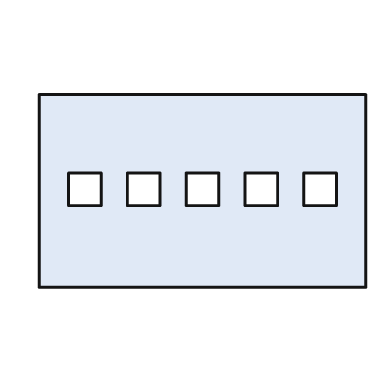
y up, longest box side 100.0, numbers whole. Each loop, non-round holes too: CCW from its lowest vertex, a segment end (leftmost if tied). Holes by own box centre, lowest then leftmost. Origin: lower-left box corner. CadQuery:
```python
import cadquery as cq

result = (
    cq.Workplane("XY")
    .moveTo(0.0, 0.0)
    .lineTo(100.0, 0.0)
    .lineTo(100.0, 59.0)
    .lineTo(0.0, 59.0)
    .close()
    .moveTo(9.0, 25.0)
    .lineTo(19.0, 25.0)
    .lineTo(19.0, 35.0)
    .lineTo(9.0, 35.0)
    .close()
    .moveTo(27.0, 25.0)
    .lineTo(37.0, 25.0)
    .lineTo(37.0, 35.0)
    .lineTo(27.0, 35.0)
    .close()
    .moveTo(45.0, 25.0)
    .lineTo(55.0, 25.0)
    .lineTo(55.0, 35.0)
    .lineTo(45.0, 35.0)
    .close()
    .moveTo(63.0, 25.0)
    .lineTo(73.0, 25.0)
    .lineTo(73.0, 35.0)
    .lineTo(63.0, 35.0)
    .close()
    .moveTo(81.0, 25.0)
    .lineTo(91.0, 25.0)
    .lineTo(91.0, 35.0)
    .lineTo(81.0, 35.0)
    .close()
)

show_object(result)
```